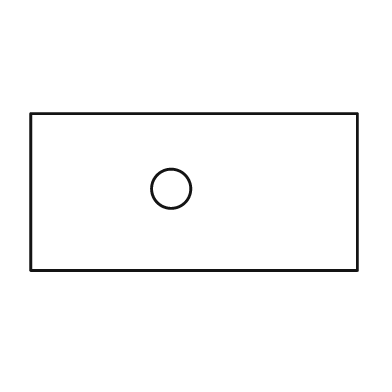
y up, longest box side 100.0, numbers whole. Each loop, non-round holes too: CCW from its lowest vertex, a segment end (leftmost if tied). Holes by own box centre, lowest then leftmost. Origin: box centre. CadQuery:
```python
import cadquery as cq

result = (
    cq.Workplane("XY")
    .moveTo(-50.0, -24.0)
    .lineTo(50.0, -24.0)
    .lineTo(50.0, 24.0)
    .lineTo(-50.0, 24.0)
    .close()
    .moveTo(-7.0, 1.0)
    .circle(6.0)
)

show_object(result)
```